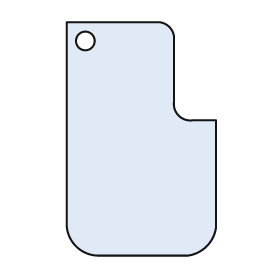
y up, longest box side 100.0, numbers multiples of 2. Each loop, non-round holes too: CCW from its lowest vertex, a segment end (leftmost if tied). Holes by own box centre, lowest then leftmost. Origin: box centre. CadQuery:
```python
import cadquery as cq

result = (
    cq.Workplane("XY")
    .moveTo(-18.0, -50.0)
    .lineTo(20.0, -50.0)
    .threePointArc((28.0, -46.0), (32.0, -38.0))
    .lineTo(32.0, 8.0)
    .lineTo(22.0, 8.0)
    .threePointArc((16.0, 10.0), (14.0, 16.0))
    .lineTo(14.0, 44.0)
    .threePointArc((12.0, 48.0), (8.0, 50.0))
    .lineTo(-32.0, 50.0)
    .lineTo(-32.0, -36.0)
    .threePointArc((-28.0, -46.0), (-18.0, -50.0))
    .close()
    .moveTo(-24.0, 42.0)
    .circle(4.0)
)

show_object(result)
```